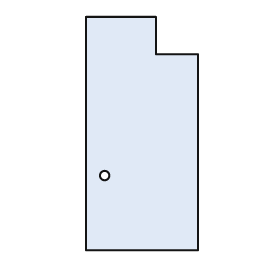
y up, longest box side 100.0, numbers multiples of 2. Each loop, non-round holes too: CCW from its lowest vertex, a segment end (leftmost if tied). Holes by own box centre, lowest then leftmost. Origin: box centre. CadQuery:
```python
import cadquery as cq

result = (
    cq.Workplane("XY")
    .moveTo(-24.0, -50.0)
    .lineTo(24.0, -50.0)
    .lineTo(24.0, 34.0)
    .lineTo(6.0, 34.0)
    .lineTo(6.0, 50.0)
    .lineTo(-24.0, 50.0)
    .close()
    .moveTo(-16.0, -18.0)
    .circle(2.0)
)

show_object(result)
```